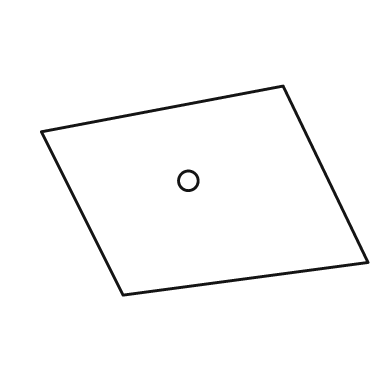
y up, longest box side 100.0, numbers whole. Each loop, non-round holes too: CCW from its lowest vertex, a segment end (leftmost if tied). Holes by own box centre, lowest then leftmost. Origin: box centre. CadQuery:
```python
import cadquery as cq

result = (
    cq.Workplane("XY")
    .moveTo(-25.0, -32.0)
    .lineTo(50.0, -22.0)
    .lineTo(24.0, 32.0)
    .lineTo(-50.0, 18.0)
    .close()
    .moveTo(-5.0, 3.0)
    .circle(3.0)
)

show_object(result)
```